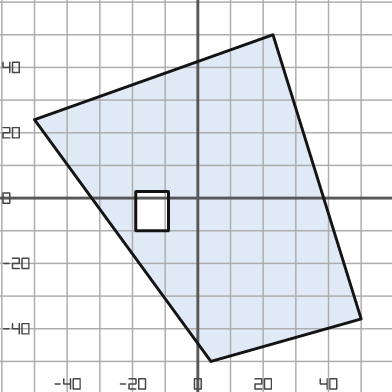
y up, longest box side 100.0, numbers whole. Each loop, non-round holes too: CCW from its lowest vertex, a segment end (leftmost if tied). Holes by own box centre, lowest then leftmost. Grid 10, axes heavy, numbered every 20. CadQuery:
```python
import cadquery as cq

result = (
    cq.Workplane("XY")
    .moveTo(4.0, -50.0)
    .lineTo(50.0, -37.0)
    .lineTo(23.0, 50.0)
    .lineTo(-50.0, 24.0)
    .close()
    .moveTo(-19.0, -10.0)
    .lineTo(-9.0, -10.0)
    .lineTo(-9.0, 2.0)
    .lineTo(-19.0, 2.0)
    .close()
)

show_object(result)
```